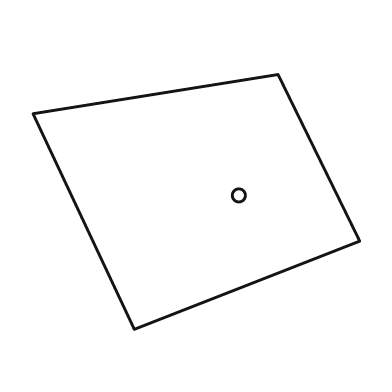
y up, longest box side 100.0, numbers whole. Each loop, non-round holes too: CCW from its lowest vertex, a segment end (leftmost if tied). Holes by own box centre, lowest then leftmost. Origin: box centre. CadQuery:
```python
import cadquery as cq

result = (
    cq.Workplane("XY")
    .moveTo(-19.0, -39.0)
    .lineTo(50.0, -12.0)
    .lineTo(25.0, 39.0)
    .lineTo(-50.0, 27.0)
    .close()
    .moveTo(13.0, 2.0)
    .circle(2.0)
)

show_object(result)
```